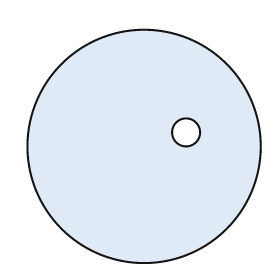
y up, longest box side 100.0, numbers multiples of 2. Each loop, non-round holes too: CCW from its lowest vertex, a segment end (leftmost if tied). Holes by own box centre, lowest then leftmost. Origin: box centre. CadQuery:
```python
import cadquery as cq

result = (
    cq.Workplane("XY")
    .moveTo(0.0, 0.0)
    .circle(50.0)
    .moveTo(18.0, 6.0)
    .circle(6.0)
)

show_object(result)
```